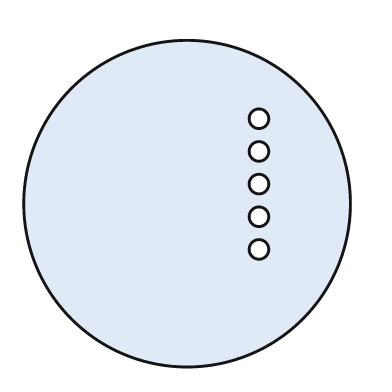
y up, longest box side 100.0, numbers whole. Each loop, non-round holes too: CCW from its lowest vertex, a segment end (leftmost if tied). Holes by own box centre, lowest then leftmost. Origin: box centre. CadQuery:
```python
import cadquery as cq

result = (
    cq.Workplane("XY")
    .moveTo(0.0, 0.0)
    .circle(50.0)
    .moveTo(22.0, -14.0)
    .circle(3.0)
    .moveTo(22.0, -4.0)
    .circle(3.0)
    .moveTo(22.0, 6.0)
    .circle(3.0)
    .moveTo(22.0, 16.0)
    .circle(3.0)
    .moveTo(22.0, 26.0)
    .circle(3.0)
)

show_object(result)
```